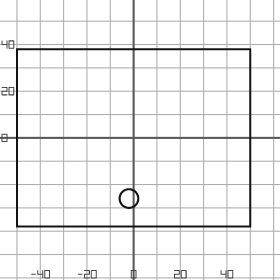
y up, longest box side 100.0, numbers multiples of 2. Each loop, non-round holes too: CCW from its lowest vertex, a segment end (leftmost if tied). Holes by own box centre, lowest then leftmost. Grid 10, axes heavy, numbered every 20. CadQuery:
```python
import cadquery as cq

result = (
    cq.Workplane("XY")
    .moveTo(-50.0, -38.0)
    .lineTo(50.0, -38.0)
    .lineTo(50.0, 38.0)
    .lineTo(-50.0, 38.0)
    .close()
    .moveTo(-2.0, -26.0)
    .circle(4.0)
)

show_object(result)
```